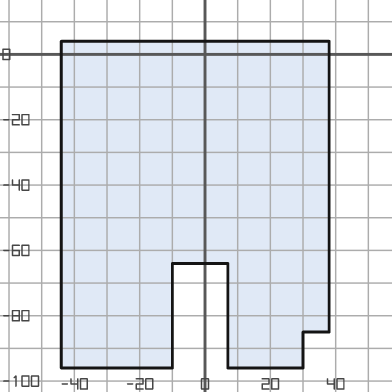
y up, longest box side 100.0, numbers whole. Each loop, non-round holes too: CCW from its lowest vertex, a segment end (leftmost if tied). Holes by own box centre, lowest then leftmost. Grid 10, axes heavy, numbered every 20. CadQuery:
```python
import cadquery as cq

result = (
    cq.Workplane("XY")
    .moveTo(-44.0, -96.0)
    .lineTo(-10.0, -96.0)
    .lineTo(-10.0, -64.0)
    .lineTo(7.0, -64.0)
    .lineTo(7.0, -96.0)
    .lineTo(30.0, -96.0)
    .lineTo(30.0, -85.0)
    .lineTo(38.0, -85.0)
    .lineTo(38.0, 4.0)
    .lineTo(-44.0, 4.0)
    .close()
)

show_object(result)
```